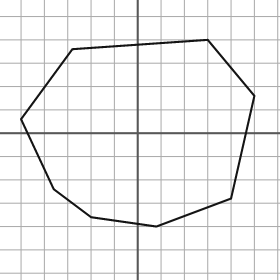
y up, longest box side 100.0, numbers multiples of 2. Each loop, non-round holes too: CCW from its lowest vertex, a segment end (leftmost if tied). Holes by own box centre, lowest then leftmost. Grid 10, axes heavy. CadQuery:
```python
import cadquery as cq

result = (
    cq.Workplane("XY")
    .moveTo(8.0, -40.0)
    .lineTo(40.0, -28.0)
    .lineTo(50.0, 16.0)
    .lineTo(30.0, 40.0)
    .lineTo(-28.0, 36.0)
    .lineTo(-50.0, 6.0)
    .lineTo(-36.0, -24.0)
    .lineTo(-20.0, -36.0)
    .close()
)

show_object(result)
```